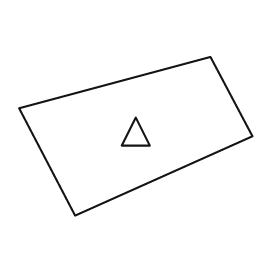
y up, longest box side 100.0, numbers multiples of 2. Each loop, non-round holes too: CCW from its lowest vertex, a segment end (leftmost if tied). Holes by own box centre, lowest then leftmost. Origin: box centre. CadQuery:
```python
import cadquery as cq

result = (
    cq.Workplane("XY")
    .moveTo(-26.0, -34.0)
    .lineTo(50.0, 0.0)
    .lineTo(32.0, 34.0)
    .lineTo(-50.0, 12.0)
    .close()
    .moveTo(-6.0, -4.0)
    .lineTo(6.0, -4.0)
    .lineTo(0.0, 8.0)
    .close()
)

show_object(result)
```